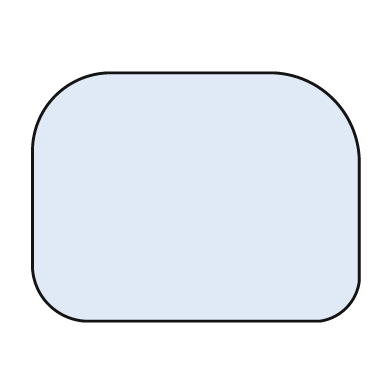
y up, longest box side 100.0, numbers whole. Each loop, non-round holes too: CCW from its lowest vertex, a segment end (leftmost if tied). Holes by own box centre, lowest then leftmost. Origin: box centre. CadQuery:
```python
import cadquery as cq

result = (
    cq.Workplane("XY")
    .moveTo(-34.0, -38.0)
    .lineTo(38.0, -38.0)
    .threePointArc((46.0, -34.0), (50.0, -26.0))
    .lineTo(50.0, 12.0)
    .threePointArc((42.0, 30.0), (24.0, 38.0))
    .lineTo(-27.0, 38.0)
    .threePointArc((-43.0, 31.0), (-50.0, 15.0))
    .lineTo(-50.0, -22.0)
    .threePointArc((-45.0, -33.0), (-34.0, -38.0))
    .close()
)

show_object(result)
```